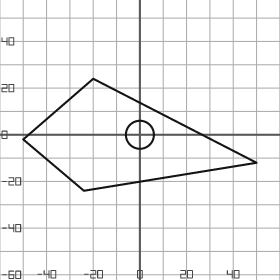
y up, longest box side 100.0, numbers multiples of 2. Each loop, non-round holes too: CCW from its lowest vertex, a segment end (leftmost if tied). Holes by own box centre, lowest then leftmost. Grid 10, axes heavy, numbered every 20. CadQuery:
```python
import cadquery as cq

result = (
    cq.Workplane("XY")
    .moveTo(-24.0, -24.0)
    .lineTo(50.0, -12.0)
    .lineTo(-20.0, 24.0)
    .lineTo(-50.0, -2.0)
    .close()
    .moveTo(0.0, 0.0)
    .circle(6.0)
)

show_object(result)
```